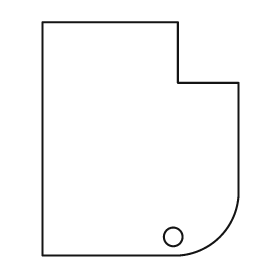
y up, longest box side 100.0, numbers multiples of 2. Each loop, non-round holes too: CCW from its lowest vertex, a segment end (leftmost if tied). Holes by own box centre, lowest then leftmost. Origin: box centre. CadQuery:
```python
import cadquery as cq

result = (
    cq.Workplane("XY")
    .moveTo(-42.0, -50.0)
    .lineTo(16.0, -50.0)
    .threePointArc((34.0, -42.0), (42.0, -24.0))
    .lineTo(42.0, 24.0)
    .lineTo(16.0, 24.0)
    .lineTo(16.0, 50.0)
    .lineTo(-42.0, 50.0)
    .close()
    .moveTo(14.0, -42.0)
    .circle(4.0)
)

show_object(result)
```